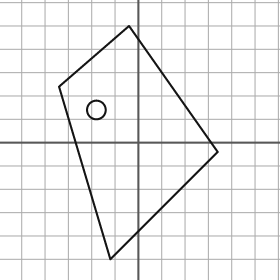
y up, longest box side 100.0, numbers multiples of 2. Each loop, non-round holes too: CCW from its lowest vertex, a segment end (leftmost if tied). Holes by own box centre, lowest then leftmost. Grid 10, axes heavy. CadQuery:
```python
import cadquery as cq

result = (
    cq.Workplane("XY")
    .moveTo(-12.0, -50.0)
    .lineTo(34.0, -4.0)
    .lineTo(-4.0, 50.0)
    .lineTo(-34.0, 24.0)
    .close()
    .moveTo(-18.0, 14.0)
    .circle(4.0)
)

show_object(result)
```